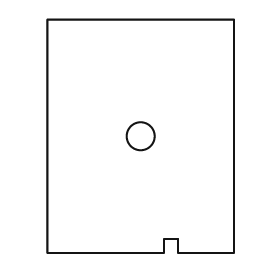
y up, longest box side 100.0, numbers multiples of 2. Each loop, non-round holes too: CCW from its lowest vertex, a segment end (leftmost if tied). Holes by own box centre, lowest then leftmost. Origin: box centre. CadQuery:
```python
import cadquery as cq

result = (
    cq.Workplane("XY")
    .moveTo(-40.0, -50.0)
    .lineTo(10.0, -50.0)
    .lineTo(10.0, -44.0)
    .lineTo(16.0, -44.0)
    .lineTo(16.0, -50.0)
    .lineTo(40.0, -50.0)
    .lineTo(40.0, 50.0)
    .lineTo(-40.0, 50.0)
    .close()
    .moveTo(0.0, 0.0)
    .circle(6.0)
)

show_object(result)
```